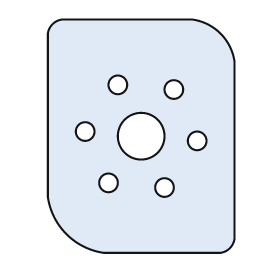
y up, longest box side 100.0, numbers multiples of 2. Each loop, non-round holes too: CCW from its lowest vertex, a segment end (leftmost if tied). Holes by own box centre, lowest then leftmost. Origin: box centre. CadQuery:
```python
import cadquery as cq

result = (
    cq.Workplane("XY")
    .moveTo(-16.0, -50.0)
    .lineTo(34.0, -50.0)
    .threePointArc((38.0, -48.0), (40.0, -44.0))
    .lineTo(40.0, 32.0)
    .threePointArc((34.0, 44.0), (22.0, 50.0))
    .lineTo(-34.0, 50.0)
    .threePointArc((-38.0, 48.0), (-40.0, 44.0))
    .lineTo(-40.0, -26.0)
    .threePointArc((-32.0, -42.0), (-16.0, -50.0))
    .close()
    .moveTo(10.0, -22.0)
    .circle(4.0)
    .moveTo(-14.0, -20.0)
    .circle(4.0)
    .moveTo(24.0, -2.0)
    .circle(4.0)
    .moveTo(0.0, 0.0)
    .circle(10.0)
    .moveTo(-24.0, 2.0)
    .circle(4.0)
    .moveTo(14.0, 20.0)
    .circle(4.0)
    .moveTo(-10.0, 22.0)
    .circle(4.0)
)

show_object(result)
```